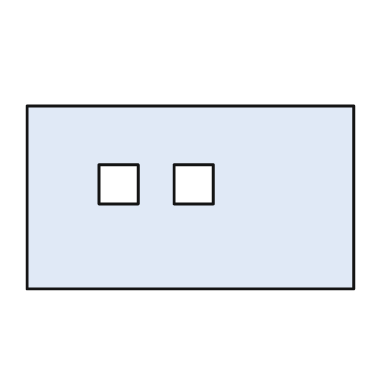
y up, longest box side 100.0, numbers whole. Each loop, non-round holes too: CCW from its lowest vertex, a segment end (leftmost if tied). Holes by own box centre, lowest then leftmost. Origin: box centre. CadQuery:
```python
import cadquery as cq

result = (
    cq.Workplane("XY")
    .moveTo(-50.0, -28.0)
    .lineTo(50.0, -28.0)
    .lineTo(50.0, 28.0)
    .lineTo(-50.0, 28.0)
    .close()
    .moveTo(-28.0, -2.0)
    .lineTo(-16.0, -2.0)
    .lineTo(-16.0, 10.0)
    .lineTo(-28.0, 10.0)
    .close()
    .moveTo(-5.0, -2.0)
    .lineTo(7.0, -2.0)
    .lineTo(7.0, 10.0)
    .lineTo(-5.0, 10.0)
    .close()
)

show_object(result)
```